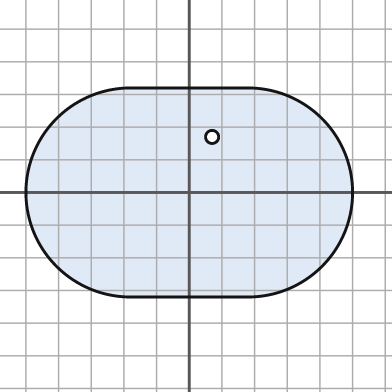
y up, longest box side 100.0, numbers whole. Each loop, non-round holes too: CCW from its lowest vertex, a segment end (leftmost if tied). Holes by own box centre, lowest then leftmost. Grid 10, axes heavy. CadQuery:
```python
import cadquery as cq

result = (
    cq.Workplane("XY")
    .moveTo(-18.0, -32.0)
    .lineTo(18.0, -32.0)
    .threePointArc((50.0, 0.0), (18.0, 32.0))
    .lineTo(-18.0, 32.0)
    .threePointArc((-50.0, 0.0), (-18.0, -32.0))
    .close()
    .moveTo(7.0, 17.0)
    .circle(2.0)
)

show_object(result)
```